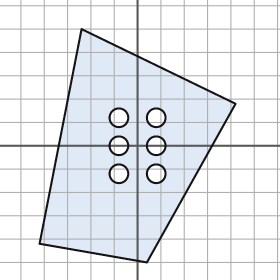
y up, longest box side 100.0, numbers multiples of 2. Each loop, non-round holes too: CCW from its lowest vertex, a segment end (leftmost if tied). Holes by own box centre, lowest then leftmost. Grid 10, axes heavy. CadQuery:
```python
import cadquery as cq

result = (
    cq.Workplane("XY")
    .moveTo(4.0, -50.0)
    .lineTo(42.0, 18.0)
    .lineTo(-24.0, 50.0)
    .lineTo(-42.0, -42.0)
    .close()
    .moveTo(-8.0, -12.0)
    .circle(4.0)
    .moveTo(8.0, -12.0)
    .circle(4.0)
    .moveTo(-8.0, 0.0)
    .circle(4.0)
    .moveTo(8.0, 0.0)
    .circle(4.0)
    .moveTo(-8.0, 12.0)
    .circle(4.0)
    .moveTo(8.0, 12.0)
    .circle(4.0)
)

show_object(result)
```